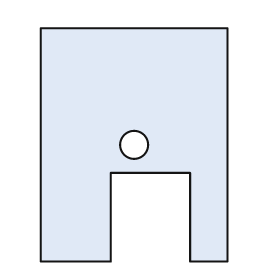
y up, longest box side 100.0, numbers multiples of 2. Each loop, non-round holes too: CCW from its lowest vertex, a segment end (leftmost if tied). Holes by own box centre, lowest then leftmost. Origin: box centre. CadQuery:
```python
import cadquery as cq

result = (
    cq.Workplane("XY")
    .moveTo(-40.0, -50.0)
    .lineTo(-10.0, -50.0)
    .lineTo(-10.0, -12.0)
    .lineTo(24.0, -12.0)
    .lineTo(24.0, -50.0)
    .lineTo(40.0, -50.0)
    .lineTo(40.0, 50.0)
    .lineTo(-40.0, 50.0)
    .close()
    .moveTo(0.0, 0.0)
    .circle(6.0)
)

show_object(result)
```